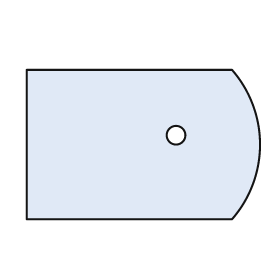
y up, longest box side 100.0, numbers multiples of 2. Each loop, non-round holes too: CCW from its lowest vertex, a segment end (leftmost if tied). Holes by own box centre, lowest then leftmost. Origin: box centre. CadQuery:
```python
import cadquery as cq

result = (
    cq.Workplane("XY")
    .moveTo(-50.0, -32.0)
    .lineTo(38.0, -32.0)
    .threePointArc((50.0, 0.0), (38.0, 32.0))
    .lineTo(-50.0, 32.0)
    .close()
    .moveTo(14.0, 4.0)
    .circle(4.0)
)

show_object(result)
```